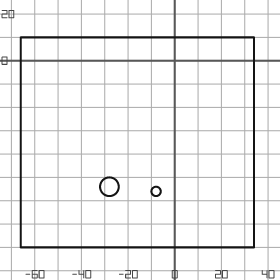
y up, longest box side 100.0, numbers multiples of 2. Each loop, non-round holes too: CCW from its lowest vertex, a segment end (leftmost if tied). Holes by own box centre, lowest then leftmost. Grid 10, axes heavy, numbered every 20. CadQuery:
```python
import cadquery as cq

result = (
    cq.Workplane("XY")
    .moveTo(-66.0, -80.0)
    .lineTo(34.0, -80.0)
    .lineTo(34.0, 10.0)
    .lineTo(-66.0, 10.0)
    .close()
    .moveTo(-8.0, -56.0)
    .circle(2.0)
    .moveTo(-28.0, -54.0)
    .circle(4.0)
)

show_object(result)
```